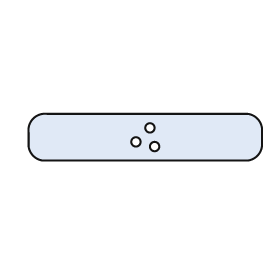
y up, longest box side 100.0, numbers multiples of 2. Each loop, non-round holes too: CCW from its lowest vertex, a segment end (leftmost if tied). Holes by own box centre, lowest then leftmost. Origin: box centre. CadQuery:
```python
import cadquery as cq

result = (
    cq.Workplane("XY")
    .moveTo(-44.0, -10.0)
    .lineTo(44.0, -10.0)
    .threePointArc((48.0, -8.0), (50.0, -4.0))
    .lineTo(50.0, 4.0)
    .threePointArc((48.0, 8.0), (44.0, 10.0))
    .lineTo(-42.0, 10.0)
    .threePointArc((-48.0, 8.0), (-50.0, 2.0))
    .lineTo(-50.0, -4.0)
    .threePointArc((-48.0, -8.0), (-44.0, -10.0))
    .close()
    .moveTo(4.0, -4.0)
    .circle(2.0)
    .moveTo(-4.0, -2.0)
    .circle(2.0)
    .moveTo(2.0, 4.0)
    .circle(2.0)
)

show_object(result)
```